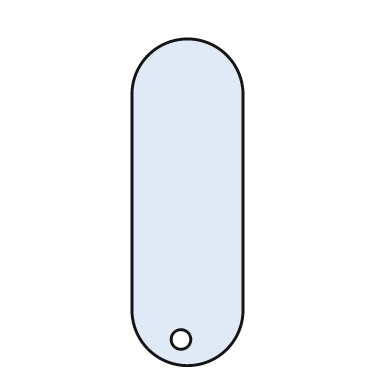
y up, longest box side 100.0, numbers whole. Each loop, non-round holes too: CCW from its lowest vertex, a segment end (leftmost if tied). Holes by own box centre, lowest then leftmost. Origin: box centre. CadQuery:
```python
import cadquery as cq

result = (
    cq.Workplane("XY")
    .moveTo(-17.0, -33.0)
    .threePointArc((0.0, -50.0), (17.0, -33.0))
    .lineTo(17.0, 33.0)
    .threePointArc((0.0, 50.0), (-17.0, 33.0))
    .close()
    .moveTo(-2.0, -42.0)
    .circle(3.0)
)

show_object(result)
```